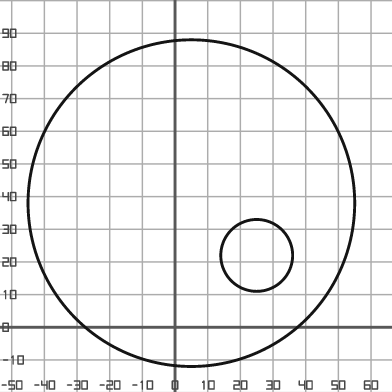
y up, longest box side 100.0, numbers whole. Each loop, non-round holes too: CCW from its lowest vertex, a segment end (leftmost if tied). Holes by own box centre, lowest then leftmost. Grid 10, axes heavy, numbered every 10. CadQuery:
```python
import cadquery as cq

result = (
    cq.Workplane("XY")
    .moveTo(5.0, 38.0)
    .circle(50.0)
    .moveTo(25.0, 22.0)
    .circle(11.0)
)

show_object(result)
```